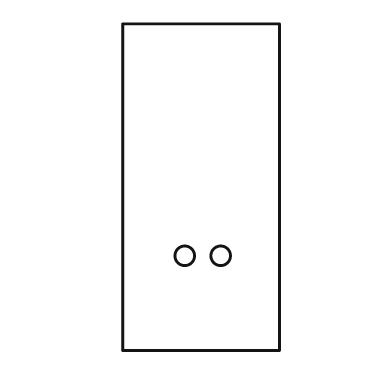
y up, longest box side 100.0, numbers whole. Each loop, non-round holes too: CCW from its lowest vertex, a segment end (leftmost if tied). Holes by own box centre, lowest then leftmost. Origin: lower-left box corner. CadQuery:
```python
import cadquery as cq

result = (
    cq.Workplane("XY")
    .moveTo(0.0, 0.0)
    .lineTo(48.0, 0.0)
    .lineTo(48.0, 100.0)
    .lineTo(0.0, 100.0)
    .close()
    .moveTo(19.0, 29.0)
    .circle(3.0)
    .moveTo(30.0, 29.0)
    .circle(3.0)
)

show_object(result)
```